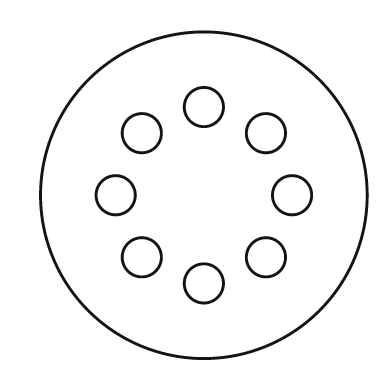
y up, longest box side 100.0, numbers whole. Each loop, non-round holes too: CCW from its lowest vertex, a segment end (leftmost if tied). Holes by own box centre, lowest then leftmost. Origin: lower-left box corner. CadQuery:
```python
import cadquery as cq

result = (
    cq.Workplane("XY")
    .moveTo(50.0, 50.0)
    .circle(50.0)
    .moveTo(50.0, 23.0)
    .circle(6.0)
    .moveTo(31.0, 31.0)
    .circle(6.0)
    .moveTo(69.0, 31.0)
    .circle(6.0)
    .moveTo(23.0, 50.0)
    .circle(6.0)
    .moveTo(77.0, 50.0)
    .circle(6.0)
    .moveTo(31.0, 69.0)
    .circle(6.0)
    .moveTo(69.0, 69.0)
    .circle(6.0)
    .moveTo(50.0, 77.0)
    .circle(6.0)
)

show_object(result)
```